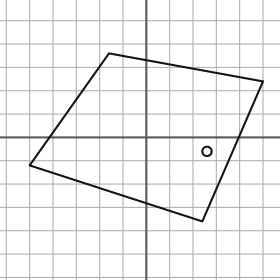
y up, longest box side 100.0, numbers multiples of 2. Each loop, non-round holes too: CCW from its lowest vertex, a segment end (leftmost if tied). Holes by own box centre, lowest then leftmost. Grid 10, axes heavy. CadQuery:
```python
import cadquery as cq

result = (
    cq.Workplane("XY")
    .moveTo(24.0, -36.0)
    .lineTo(50.0, 24.0)
    .lineTo(-16.0, 36.0)
    .lineTo(-50.0, -12.0)
    .close()
    .moveTo(26.0, -6.0)
    .circle(2.0)
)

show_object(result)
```